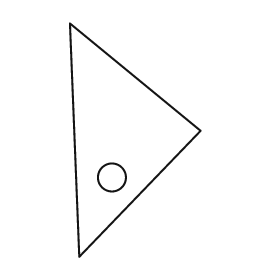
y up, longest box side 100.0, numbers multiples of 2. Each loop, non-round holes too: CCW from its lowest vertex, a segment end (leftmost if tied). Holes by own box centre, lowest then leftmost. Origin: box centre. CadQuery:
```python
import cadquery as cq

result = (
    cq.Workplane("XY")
    .moveTo(-24.0, -50.0)
    .lineTo(28.0, 4.0)
    .lineTo(-28.0, 50.0)
    .close()
    .moveTo(-10.0, -16.0)
    .circle(6.0)
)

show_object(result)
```